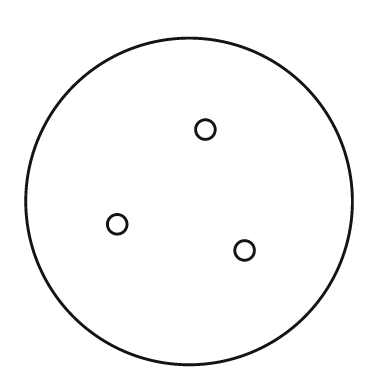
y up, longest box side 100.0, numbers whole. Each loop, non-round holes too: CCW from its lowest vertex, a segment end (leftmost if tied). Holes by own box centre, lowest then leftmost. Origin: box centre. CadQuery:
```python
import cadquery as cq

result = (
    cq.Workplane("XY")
    .moveTo(0.0, 0.0)
    .circle(50.0)
    .moveTo(17.0, -15.0)
    .circle(3.0)
    .moveTo(-22.0, -7.0)
    .circle(3.0)
    .moveTo(5.0, 22.0)
    .circle(3.0)
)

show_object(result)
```